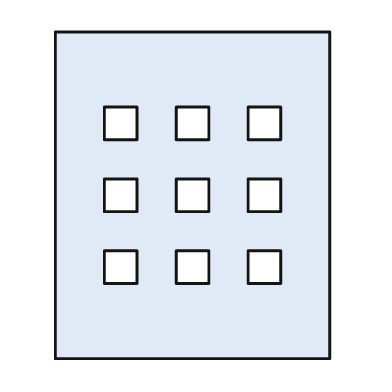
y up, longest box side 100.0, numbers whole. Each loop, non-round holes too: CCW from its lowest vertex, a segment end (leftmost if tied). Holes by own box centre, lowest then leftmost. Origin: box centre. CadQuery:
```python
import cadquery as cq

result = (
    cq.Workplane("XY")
    .moveTo(-42.0, -50.0)
    .lineTo(42.0, -50.0)
    .lineTo(42.0, 50.0)
    .lineTo(-42.0, 50.0)
    .close()
    .moveTo(-27.0, -27.0)
    .lineTo(-17.0, -27.0)
    .lineTo(-17.0, -17.0)
    .lineTo(-27.0, -17.0)
    .close()
    .moveTo(-5.0, -27.0)
    .lineTo(5.0, -27.0)
    .lineTo(5.0, -17.0)
    .lineTo(-5.0, -17.0)
    .close()
    .moveTo(17.0, -27.0)
    .lineTo(27.0, -27.0)
    .lineTo(27.0, -17.0)
    .lineTo(17.0, -17.0)
    .close()
    .moveTo(-27.0, -5.0)
    .lineTo(-17.0, -5.0)
    .lineTo(-17.0, 5.0)
    .lineTo(-27.0, 5.0)
    .close()
    .moveTo(-5.0, -5.0)
    .lineTo(5.0, -5.0)
    .lineTo(5.0, 5.0)
    .lineTo(-5.0, 5.0)
    .close()
    .moveTo(17.0, -5.0)
    .lineTo(27.0, -5.0)
    .lineTo(27.0, 5.0)
    .lineTo(17.0, 5.0)
    .close()
    .moveTo(-27.0, 17.0)
    .lineTo(-17.0, 17.0)
    .lineTo(-17.0, 27.0)
    .lineTo(-27.0, 27.0)
    .close()
    .moveTo(-5.0, 17.0)
    .lineTo(5.0, 17.0)
    .lineTo(5.0, 27.0)
    .lineTo(-5.0, 27.0)
    .close()
    .moveTo(17.0, 17.0)
    .lineTo(27.0, 17.0)
    .lineTo(27.0, 27.0)
    .lineTo(17.0, 27.0)
    .close()
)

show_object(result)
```